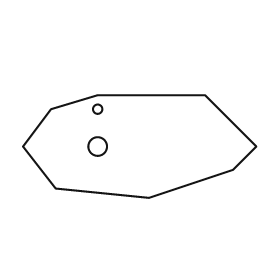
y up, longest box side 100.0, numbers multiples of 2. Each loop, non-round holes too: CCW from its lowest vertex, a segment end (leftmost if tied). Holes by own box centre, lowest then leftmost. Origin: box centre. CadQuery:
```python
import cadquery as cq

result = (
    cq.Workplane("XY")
    .moveTo(4.0, -22.0)
    .lineTo(40.0, -10.0)
    .lineTo(50.0, 0.0)
    .lineTo(28.0, 22.0)
    .lineTo(-18.0, 22.0)
    .lineTo(-38.0, 16.0)
    .lineTo(-50.0, 0.0)
    .lineTo(-36.0, -18.0)
    .close()
    .moveTo(-18.0, 0.0)
    .circle(4.0)
    .moveTo(-18.0, 16.0)
    .circle(2.0)
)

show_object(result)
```